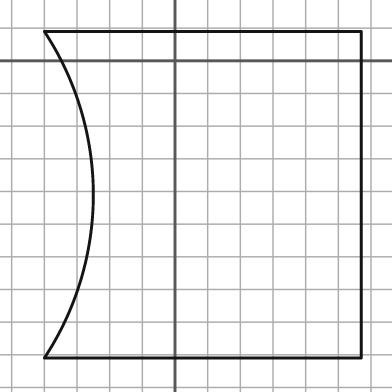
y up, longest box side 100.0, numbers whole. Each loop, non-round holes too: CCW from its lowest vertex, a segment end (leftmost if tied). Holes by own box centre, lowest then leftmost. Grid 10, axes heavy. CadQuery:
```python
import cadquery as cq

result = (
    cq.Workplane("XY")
    .moveTo(-40.0, -91.0)
    .lineTo(57.0, -91.0)
    .lineTo(57.0, 9.0)
    .lineTo(-40.0, 9.0)
    .threePointArc((-25.0, -41.0), (-40.0, -91.0))
    .close()
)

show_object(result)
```